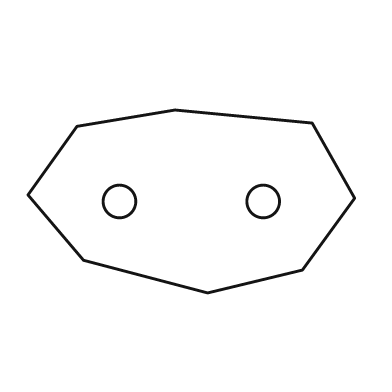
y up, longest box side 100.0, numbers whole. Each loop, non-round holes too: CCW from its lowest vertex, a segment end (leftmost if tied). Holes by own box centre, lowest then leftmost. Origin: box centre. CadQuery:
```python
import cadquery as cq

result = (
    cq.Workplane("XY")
    .moveTo(5.0, -28.0)
    .lineTo(34.0, -21.0)
    .lineTo(50.0, 1.0)
    .lineTo(37.0, 24.0)
    .lineTo(-5.0, 28.0)
    .lineTo(-35.0, 23.0)
    .lineTo(-50.0, 2.0)
    .lineTo(-33.0, -18.0)
    .close()
    .moveTo(-22.0, 0.0)
    .circle(5.0)
    .moveTo(22.0, 0.0)
    .circle(5.0)
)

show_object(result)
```